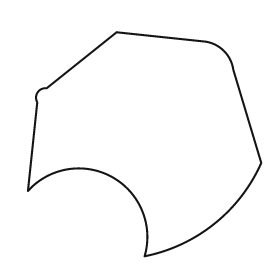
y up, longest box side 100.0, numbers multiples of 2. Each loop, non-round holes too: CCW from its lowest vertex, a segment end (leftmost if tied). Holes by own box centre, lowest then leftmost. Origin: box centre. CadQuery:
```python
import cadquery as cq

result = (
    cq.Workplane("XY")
    .moveTo(0.0, -48.0)
    .threePointArc((30.0, -34.0), (50.0, -8.0))
    .lineTo(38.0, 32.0)
    .threePointArc((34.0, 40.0), (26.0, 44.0))
    .lineTo(-12.0, 48.0)
    .lineTo(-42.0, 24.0)
    .threePointArc((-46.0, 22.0), (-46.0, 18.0))
    .lineTo(-50.0, -20.0)
    .threePointArc((-14.0, -14.0), (0.0, -48.0))
    .close()
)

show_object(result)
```